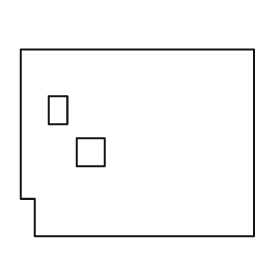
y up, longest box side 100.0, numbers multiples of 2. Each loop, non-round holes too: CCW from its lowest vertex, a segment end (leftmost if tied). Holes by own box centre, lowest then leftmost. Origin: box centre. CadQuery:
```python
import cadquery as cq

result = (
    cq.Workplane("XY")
    .moveTo(-44.0, -40.0)
    .lineTo(50.0, -40.0)
    .lineTo(50.0, 40.0)
    .lineTo(-50.0, 40.0)
    .lineTo(-50.0, -24.0)
    .lineTo(-44.0, -24.0)
    .close()
    .moveTo(-26.0, -10.0)
    .lineTo(-14.0, -10.0)
    .lineTo(-14.0, 2.0)
    .lineTo(-26.0, 2.0)
    .close()
    .moveTo(-38.0, 8.0)
    .lineTo(-30.0, 8.0)
    .lineTo(-30.0, 20.0)
    .lineTo(-38.0, 20.0)
    .close()
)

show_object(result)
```